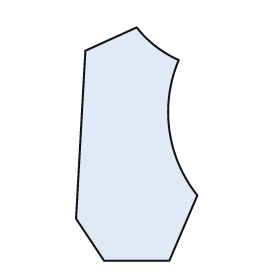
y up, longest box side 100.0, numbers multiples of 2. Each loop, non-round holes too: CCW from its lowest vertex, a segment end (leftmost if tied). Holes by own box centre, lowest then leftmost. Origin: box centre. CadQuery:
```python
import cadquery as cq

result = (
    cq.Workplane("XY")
    .moveTo(-14.0, -50.0)
    .lineTo(14.0, -50.0)
    .lineTo(26.0, -22.0)
    .threePointArc((14.0, 6.0), (18.0, 36.0))
    .threePointArc((8.0, 42.0), (0.0, 50.0))
    .lineTo(-22.0, 40.0)
    .lineTo(-26.0, -32.0)
    .close()
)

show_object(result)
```